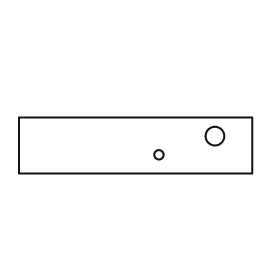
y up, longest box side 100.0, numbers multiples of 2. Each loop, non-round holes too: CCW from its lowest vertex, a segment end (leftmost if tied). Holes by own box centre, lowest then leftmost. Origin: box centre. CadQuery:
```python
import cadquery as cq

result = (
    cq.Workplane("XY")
    .moveTo(-50.0, -12.0)
    .lineTo(50.0, -12.0)
    .lineTo(50.0, 12.0)
    .lineTo(-50.0, 12.0)
    .close()
    .moveTo(10.0, -4.0)
    .circle(2.0)
    .moveTo(34.0, 4.0)
    .circle(4.0)
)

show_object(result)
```